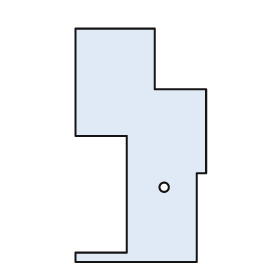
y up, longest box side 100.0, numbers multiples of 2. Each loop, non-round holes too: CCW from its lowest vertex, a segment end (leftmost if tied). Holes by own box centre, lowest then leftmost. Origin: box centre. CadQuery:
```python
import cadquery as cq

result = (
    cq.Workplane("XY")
    .moveTo(-28.0, -50.0)
    .lineTo(24.0, -50.0)
    .lineTo(24.0, -12.0)
    .lineTo(28.0, -12.0)
    .lineTo(28.0, 24.0)
    .lineTo(6.0, 24.0)
    .lineTo(6.0, 50.0)
    .lineTo(-28.0, 50.0)
    .lineTo(-28.0, 4.0)
    .lineTo(-6.0, 4.0)
    .lineTo(-6.0, -46.0)
    .lineTo(-28.0, -46.0)
    .close()
    .moveTo(10.0, -18.0)
    .circle(2.0)
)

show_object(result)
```